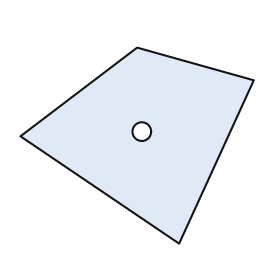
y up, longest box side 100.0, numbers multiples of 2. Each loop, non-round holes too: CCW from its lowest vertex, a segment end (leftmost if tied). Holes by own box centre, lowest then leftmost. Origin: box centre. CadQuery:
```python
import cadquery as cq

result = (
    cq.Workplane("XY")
    .moveTo(18.0, -42.0)
    .lineTo(50.0, 28.0)
    .lineTo(0.0, 42.0)
    .lineTo(-50.0, 4.0)
    .close()
    .moveTo(2.0, 6.0)
    .circle(4.0)
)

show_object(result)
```